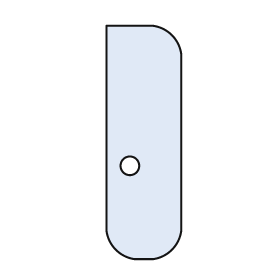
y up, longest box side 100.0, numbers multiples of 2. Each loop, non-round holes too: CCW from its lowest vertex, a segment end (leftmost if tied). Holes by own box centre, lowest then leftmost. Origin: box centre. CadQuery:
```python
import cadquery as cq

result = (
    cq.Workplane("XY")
    .moveTo(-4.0, -50.0)
    .lineTo(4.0, -50.0)
    .threePointArc((12.0, -46.0), (16.0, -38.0))
    .lineTo(16.0, 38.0)
    .threePointArc((12.0, 46.0), (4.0, 50.0))
    .lineTo(-16.0, 50.0)
    .lineTo(-16.0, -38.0)
    .threePointArc((-12.0, -46.0), (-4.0, -50.0))
    .close()
    .moveTo(-6.0, -10.0)
    .circle(4.0)
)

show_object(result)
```